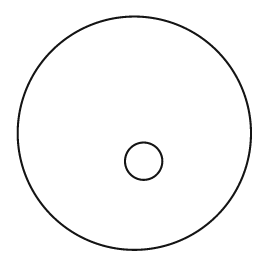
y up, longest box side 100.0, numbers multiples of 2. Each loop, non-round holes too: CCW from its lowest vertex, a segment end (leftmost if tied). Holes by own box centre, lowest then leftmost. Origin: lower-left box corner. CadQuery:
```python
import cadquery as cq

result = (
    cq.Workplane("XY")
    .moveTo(50.0, 50.0)
    .circle(50.0)
    .moveTo(54.0, 38.0)
    .circle(8.0)
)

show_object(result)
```